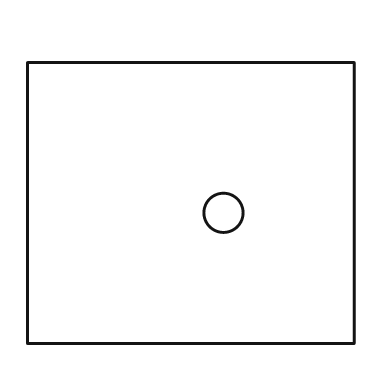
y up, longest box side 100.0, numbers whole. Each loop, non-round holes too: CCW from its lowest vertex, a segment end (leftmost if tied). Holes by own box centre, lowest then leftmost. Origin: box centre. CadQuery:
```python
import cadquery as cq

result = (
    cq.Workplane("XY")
    .moveTo(-50.0, -43.0)
    .lineTo(50.0, -43.0)
    .lineTo(50.0, 43.0)
    .lineTo(-50.0, 43.0)
    .close()
    .moveTo(10.0, -3.0)
    .circle(6.0)
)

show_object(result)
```